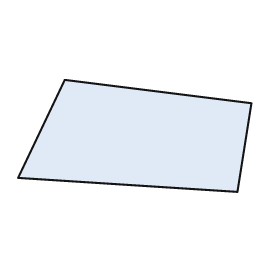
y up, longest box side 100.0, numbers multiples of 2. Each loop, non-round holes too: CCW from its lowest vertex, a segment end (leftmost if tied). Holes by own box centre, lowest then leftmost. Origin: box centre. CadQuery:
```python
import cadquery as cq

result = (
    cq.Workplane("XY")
    .moveTo(44.0, -24.0)
    .lineTo(50.0, 14.0)
    .lineTo(-30.0, 24.0)
    .lineTo(-50.0, -18.0)
    .close()
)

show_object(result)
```